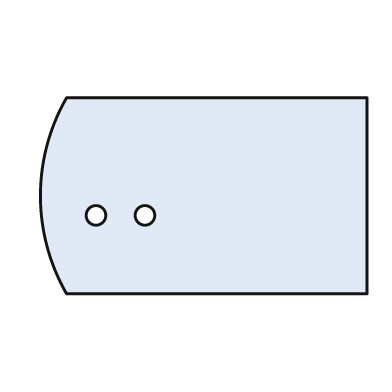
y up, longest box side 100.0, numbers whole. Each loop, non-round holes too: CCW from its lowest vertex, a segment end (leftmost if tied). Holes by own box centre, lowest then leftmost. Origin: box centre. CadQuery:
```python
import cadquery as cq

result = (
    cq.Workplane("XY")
    .moveTo(-42.0, -30.0)
    .lineTo(50.0, -30.0)
    .lineTo(50.0, 30.0)
    .lineTo(-42.0, 30.0)
    .threePointArc((-50.0, 0.0), (-42.0, -30.0))
    .close()
    .moveTo(-33.0, -6.0)
    .circle(3.0)
    .moveTo(-18.0, -6.0)
    .circle(3.0)
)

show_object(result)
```